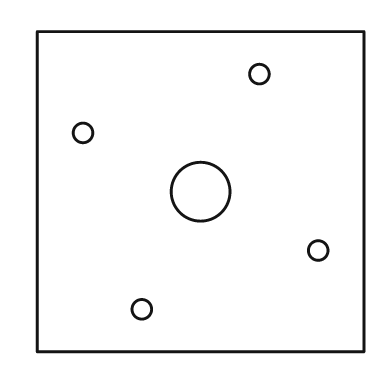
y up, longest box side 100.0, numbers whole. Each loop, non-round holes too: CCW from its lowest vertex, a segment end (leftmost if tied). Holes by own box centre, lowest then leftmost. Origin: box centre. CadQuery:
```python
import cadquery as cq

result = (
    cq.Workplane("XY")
    .moveTo(-50.0, -49.0)
    .lineTo(50.0, -49.0)
    .lineTo(50.0, 49.0)
    .lineTo(-50.0, 49.0)
    .close()
    .moveTo(-18.0, -36.0)
    .circle(3.0)
    .moveTo(36.0, -18.0)
    .circle(3.0)
    .moveTo(0.0, 0.0)
    .circle(9.0)
    .moveTo(-36.0, 18.0)
    .circle(3.0)
    .moveTo(18.0, 36.0)
    .circle(3.0)
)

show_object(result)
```